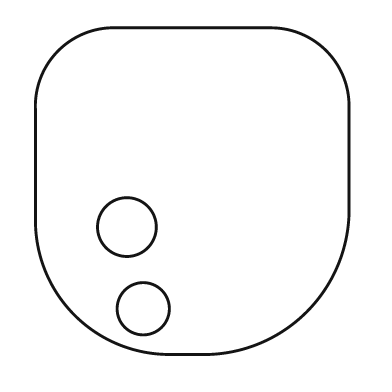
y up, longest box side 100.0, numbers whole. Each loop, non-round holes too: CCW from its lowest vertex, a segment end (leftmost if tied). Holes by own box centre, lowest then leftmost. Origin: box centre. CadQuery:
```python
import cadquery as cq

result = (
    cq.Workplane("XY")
    .moveTo(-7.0, -50.0)
    .lineTo(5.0, -50.0)
    .threePointArc((35.0, -37.0), (48.0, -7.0))
    .lineTo(48.0, 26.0)
    .threePointArc((41.0, 43.0), (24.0, 50.0))
    .lineTo(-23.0, 50.0)
    .threePointArc((-41.0, 43.0), (-48.0, 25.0))
    .lineTo(-48.0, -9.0)
    .threePointArc((-36.0, -38.0), (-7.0, -50.0))
    .close()
    .moveTo(-15.0, -36.0)
    .circle(8.0)
    .moveTo(-20.0, -11.0)
    .circle(9.0)
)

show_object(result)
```